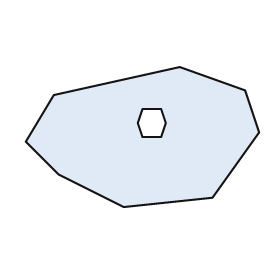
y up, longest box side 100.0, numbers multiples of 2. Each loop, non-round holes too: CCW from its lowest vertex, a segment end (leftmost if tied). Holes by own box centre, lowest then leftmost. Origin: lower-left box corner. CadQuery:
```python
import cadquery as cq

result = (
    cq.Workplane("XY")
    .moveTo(42.0, 0.0)
    .lineTo(80.0, 4.0)
    .lineTo(100.0, 32.0)
    .lineTo(94.0, 50.0)
    .lineTo(66.0, 60.0)
    .lineTo(12.0, 48.0)
    .lineTo(0.0, 28.0)
    .lineTo(14.0, 14.0)
    .close()
    .moveTo(50.0, 30.0)
    .lineTo(58.0, 30.0)
    .lineTo(60.0, 36.0)
    .lineTo(58.0, 42.0)
    .lineTo(50.0, 42.0)
    .lineTo(48.0, 36.0)
    .close()
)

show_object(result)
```